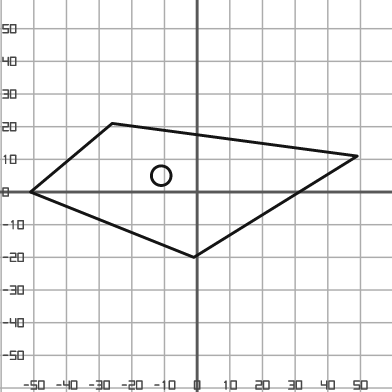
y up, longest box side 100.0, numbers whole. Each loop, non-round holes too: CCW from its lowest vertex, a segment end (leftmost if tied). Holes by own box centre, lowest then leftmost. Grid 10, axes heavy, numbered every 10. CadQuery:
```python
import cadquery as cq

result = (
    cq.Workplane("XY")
    .moveTo(-1.0, -20.0)
    .lineTo(49.0, 11.0)
    .lineTo(-26.0, 21.0)
    .lineTo(-51.0, 0.0)
    .close()
    .moveTo(-11.0, 5.0)
    .circle(3.0)
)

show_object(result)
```